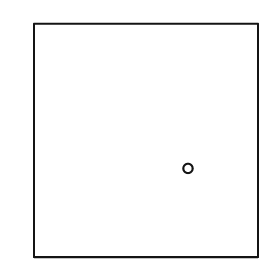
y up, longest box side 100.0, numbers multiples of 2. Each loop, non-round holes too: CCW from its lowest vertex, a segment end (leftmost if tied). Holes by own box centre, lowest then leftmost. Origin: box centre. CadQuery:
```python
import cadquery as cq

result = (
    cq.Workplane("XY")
    .moveTo(-48.0, -50.0)
    .lineTo(48.0, -50.0)
    .lineTo(48.0, 50.0)
    .lineTo(-48.0, 50.0)
    .close()
    .moveTo(18.0, -12.0)
    .circle(2.0)
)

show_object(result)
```